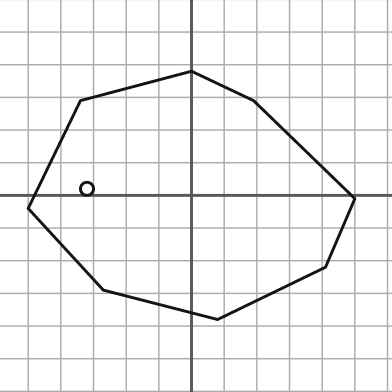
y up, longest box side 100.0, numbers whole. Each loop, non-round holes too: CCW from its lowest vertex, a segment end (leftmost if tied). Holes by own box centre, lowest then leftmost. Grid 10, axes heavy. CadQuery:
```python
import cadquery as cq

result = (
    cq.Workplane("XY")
    .moveTo(8.0, -38.0)
    .lineTo(41.0, -22.0)
    .lineTo(50.0, -1.0)
    .lineTo(19.0, 29.0)
    .lineTo(0.0, 38.0)
    .lineTo(-34.0, 29.0)
    .lineTo(-50.0, -4.0)
    .lineTo(-27.0, -29.0)
    .close()
    .moveTo(-32.0, 2.0)
    .circle(2.0)
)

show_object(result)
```